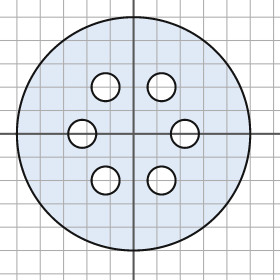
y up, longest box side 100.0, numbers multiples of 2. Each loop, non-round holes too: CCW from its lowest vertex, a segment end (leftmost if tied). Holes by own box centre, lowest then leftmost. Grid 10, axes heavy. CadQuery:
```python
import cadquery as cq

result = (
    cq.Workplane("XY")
    .moveTo(0.0, 0.0)
    .circle(50.0)
    .moveTo(-12.0, -20.0)
    .circle(6.0)
    .moveTo(12.0, -20.0)
    .circle(6.0)
    .moveTo(-22.0, 0.0)
    .circle(6.0)
    .moveTo(22.0, 0.0)
    .circle(6.0)
    .moveTo(-12.0, 20.0)
    .circle(6.0)
    .moveTo(12.0, 20.0)
    .circle(6.0)
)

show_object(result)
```